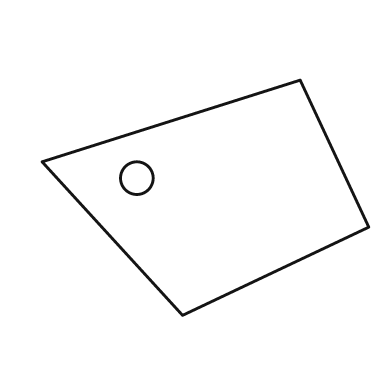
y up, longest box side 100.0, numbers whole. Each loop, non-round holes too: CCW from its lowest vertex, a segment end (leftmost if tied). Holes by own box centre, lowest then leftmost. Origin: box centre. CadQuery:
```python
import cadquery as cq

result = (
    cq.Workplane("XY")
    .moveTo(-7.0, -36.0)
    .lineTo(50.0, -9.0)
    .lineTo(29.0, 36.0)
    .lineTo(-50.0, 11.0)
    .close()
    .moveTo(-21.0, 6.0)
    .circle(5.0)
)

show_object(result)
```